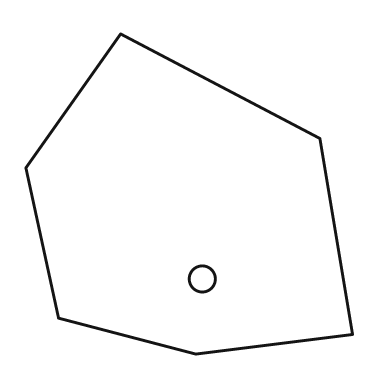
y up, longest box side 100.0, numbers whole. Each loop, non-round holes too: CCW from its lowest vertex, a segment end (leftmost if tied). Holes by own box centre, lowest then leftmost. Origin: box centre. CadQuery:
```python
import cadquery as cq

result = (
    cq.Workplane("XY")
    .moveTo(2.0, -49.0)
    .lineTo(50.0, -43.0)
    .lineTo(40.0, 17.0)
    .lineTo(-21.0, 49.0)
    .lineTo(-50.0, 8.0)
    .lineTo(-40.0, -38.0)
    .close()
    .moveTo(4.0, -26.0)
    .circle(4.0)
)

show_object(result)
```